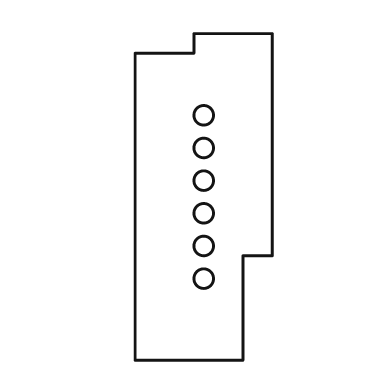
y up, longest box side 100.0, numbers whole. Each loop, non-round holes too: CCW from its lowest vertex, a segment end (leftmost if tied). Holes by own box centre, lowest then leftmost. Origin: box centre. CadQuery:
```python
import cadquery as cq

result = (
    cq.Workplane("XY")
    .moveTo(-21.0, -50.0)
    .lineTo(12.0, -50.0)
    .lineTo(12.0, -18.0)
    .lineTo(21.0, -18.0)
    .lineTo(21.0, 50.0)
    .lineTo(-3.0, 50.0)
    .lineTo(-3.0, 44.0)
    .lineTo(-21.0, 44.0)
    .close()
    .moveTo(0.0, -25.0)
    .circle(3.0)
    .moveTo(0.0, -15.0)
    .circle(3.0)
    .moveTo(0.0, -5.0)
    .circle(3.0)
    .moveTo(0.0, 5.0)
    .circle(3.0)
    .moveTo(0.0, 15.0)
    .circle(3.0)
    .moveTo(0.0, 25.0)
    .circle(3.0)
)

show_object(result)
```